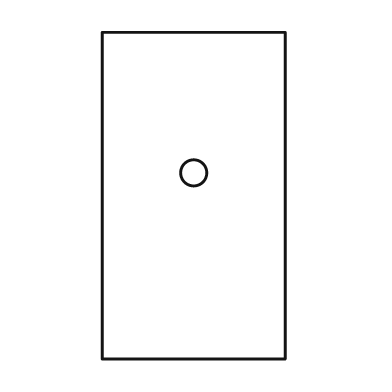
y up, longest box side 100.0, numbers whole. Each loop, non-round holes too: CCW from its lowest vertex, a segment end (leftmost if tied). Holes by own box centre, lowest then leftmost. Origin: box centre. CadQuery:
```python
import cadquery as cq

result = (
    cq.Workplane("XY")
    .moveTo(-28.0, -50.0)
    .lineTo(28.0, -50.0)
    .lineTo(28.0, 50.0)
    .lineTo(-28.0, 50.0)
    .close()
    .moveTo(0.0, 7.0)
    .circle(4.0)
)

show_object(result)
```